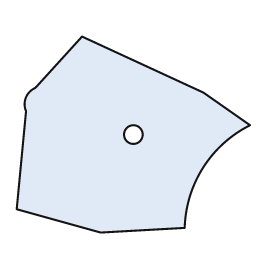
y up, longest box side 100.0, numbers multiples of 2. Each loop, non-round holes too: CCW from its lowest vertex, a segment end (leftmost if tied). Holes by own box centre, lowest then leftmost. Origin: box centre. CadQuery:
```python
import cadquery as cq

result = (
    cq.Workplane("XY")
    .moveTo(-14.0, -42.0)
    .lineTo(22.0, -40.0)
    .threePointArc((30.0, -14.0), (50.0, 4.0))
    .lineTo(30.0, 18.0)
    .lineTo(-22.0, 42.0)
    .lineTo(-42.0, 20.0)
    .threePointArc((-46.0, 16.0), (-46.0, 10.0))
    .lineTo(-50.0, -32.0)
    .close()
    .moveTo(0.0, 0.0)
    .circle(4.0)
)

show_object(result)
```